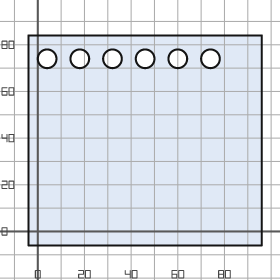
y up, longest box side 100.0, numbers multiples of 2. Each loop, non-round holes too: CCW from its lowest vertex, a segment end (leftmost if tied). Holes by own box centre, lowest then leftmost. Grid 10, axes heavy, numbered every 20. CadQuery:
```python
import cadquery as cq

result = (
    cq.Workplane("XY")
    .moveTo(-4.0, -6.0)
    .lineTo(96.0, -6.0)
    .lineTo(96.0, 84.0)
    .lineTo(-4.0, 84.0)
    .close()
    .moveTo(4.0, 74.0)
    .circle(4.0)
    .moveTo(18.0, 74.0)
    .circle(4.0)
    .moveTo(32.0, 74.0)
    .circle(4.0)
    .moveTo(46.0, 74.0)
    .circle(4.0)
    .moveTo(60.0, 74.0)
    .circle(4.0)
    .moveTo(74.0, 74.0)
    .circle(4.0)
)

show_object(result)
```